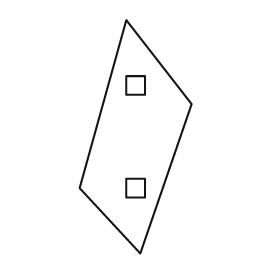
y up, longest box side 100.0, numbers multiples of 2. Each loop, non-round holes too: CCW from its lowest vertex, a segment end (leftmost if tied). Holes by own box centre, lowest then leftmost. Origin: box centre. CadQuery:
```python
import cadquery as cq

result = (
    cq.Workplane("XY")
    .moveTo(2.0, -50.0)
    .lineTo(24.0, 14.0)
    .lineTo(-4.0, 50.0)
    .lineTo(-24.0, -22.0)
    .close()
    .moveTo(-4.0, -26.0)
    .lineTo(4.0, -26.0)
    .lineTo(4.0, -18.0)
    .lineTo(-4.0, -18.0)
    .close()
    .moveTo(-4.0, 18.0)
    .lineTo(4.0, 18.0)
    .lineTo(4.0, 26.0)
    .lineTo(-4.0, 26.0)
    .close()
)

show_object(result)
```